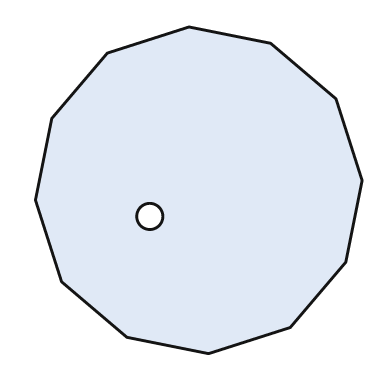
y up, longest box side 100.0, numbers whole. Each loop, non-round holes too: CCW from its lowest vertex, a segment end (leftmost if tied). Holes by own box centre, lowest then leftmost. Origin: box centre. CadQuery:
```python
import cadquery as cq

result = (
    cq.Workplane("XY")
    .moveTo(3.0, -50.0)
    .lineTo(28.0, -42.0)
    .lineTo(45.0, -22.0)
    .lineTo(50.0, 3.0)
    .lineTo(42.0, 28.0)
    .lineTo(22.0, 45.0)
    .lineTo(-3.0, 50.0)
    .lineTo(-28.0, 42.0)
    .lineTo(-45.0, 22.0)
    .lineTo(-50.0, -3.0)
    .lineTo(-42.0, -28.0)
    .lineTo(-22.0, -45.0)
    .close()
    .moveTo(-15.0, -8.0)
    .circle(4.0)
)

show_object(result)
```